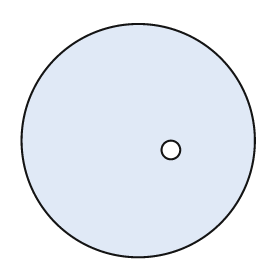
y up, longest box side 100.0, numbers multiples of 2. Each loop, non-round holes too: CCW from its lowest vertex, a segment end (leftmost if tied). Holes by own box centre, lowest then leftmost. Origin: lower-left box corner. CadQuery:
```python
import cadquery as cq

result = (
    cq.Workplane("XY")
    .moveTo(50.0, 50.0)
    .circle(50.0)
    .moveTo(64.0, 46.0)
    .circle(4.0)
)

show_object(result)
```